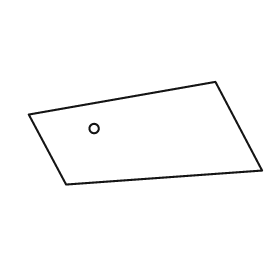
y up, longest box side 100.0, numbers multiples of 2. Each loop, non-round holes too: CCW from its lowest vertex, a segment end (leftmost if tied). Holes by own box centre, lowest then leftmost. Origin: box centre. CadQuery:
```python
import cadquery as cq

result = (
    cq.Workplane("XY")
    .moveTo(-34.0, -22.0)
    .lineTo(50.0, -16.0)
    .lineTo(30.0, 22.0)
    .lineTo(-50.0, 8.0)
    .close()
    .moveTo(-22.0, 2.0)
    .circle(2.0)
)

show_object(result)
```